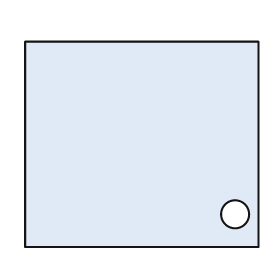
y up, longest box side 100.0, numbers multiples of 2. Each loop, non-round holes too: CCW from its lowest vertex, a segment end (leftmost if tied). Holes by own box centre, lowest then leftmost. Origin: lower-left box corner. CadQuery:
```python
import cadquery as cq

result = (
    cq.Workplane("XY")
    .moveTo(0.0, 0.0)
    .lineTo(100.0, 0.0)
    .lineTo(100.0, 88.0)
    .lineTo(0.0, 88.0)
    .close()
    .moveTo(90.0, 14.0)
    .circle(6.0)
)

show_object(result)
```